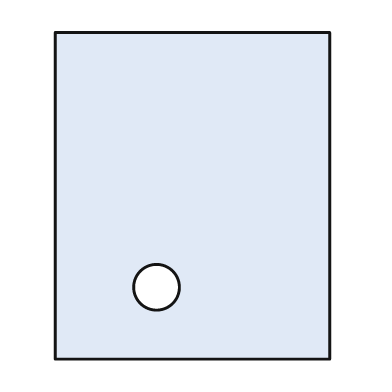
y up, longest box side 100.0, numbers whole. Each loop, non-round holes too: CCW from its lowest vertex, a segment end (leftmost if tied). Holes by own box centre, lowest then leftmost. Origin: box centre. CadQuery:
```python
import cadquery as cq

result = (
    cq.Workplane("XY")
    .moveTo(-42.0, -50.0)
    .lineTo(42.0, -50.0)
    .lineTo(42.0, 50.0)
    .lineTo(-42.0, 50.0)
    .close()
    .moveTo(-11.0, -28.0)
    .circle(7.0)
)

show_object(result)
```